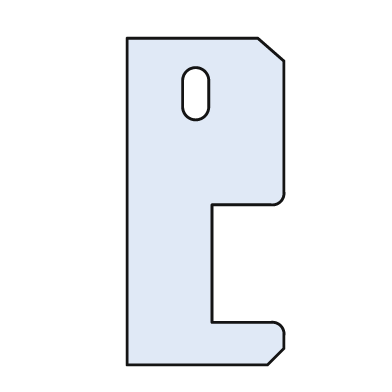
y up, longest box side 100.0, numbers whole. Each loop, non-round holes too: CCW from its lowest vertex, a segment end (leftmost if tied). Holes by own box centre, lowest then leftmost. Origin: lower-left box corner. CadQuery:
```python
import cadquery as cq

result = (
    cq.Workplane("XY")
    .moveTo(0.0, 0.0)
    .lineTo(43.0, 0.0)
    .lineTo(48.0, 5.0)
    .lineTo(48.0, 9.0)
    .threePointArc((47.0, 12.0), (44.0, 13.0))
    .lineTo(26.0, 13.0)
    .lineTo(26.0, 49.0)
    .lineTo(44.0, 49.0)
    .threePointArc((47.0, 50.0), (48.0, 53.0))
    .lineTo(48.0, 93.0)
    .lineTo(40.0, 100.0)
    .lineTo(0.0, 100.0)
    .close()
    .moveTo(17.0, 79.0)
    .threePointArc((21.0, 75.0), (25.0, 79.0))
    .lineTo(25.0, 87.0)
    .threePointArc((21.0, 91.0), (17.0, 87.0))
    .close()
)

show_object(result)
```